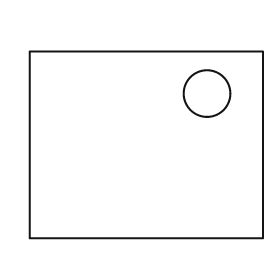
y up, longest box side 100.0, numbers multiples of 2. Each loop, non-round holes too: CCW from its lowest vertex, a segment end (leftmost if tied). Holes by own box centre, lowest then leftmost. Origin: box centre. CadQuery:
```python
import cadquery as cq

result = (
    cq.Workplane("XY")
    .moveTo(-50.0, -40.0)
    .lineTo(50.0, -40.0)
    .lineTo(50.0, 40.0)
    .lineTo(-50.0, 40.0)
    .close()
    .moveTo(26.0, 22.0)
    .circle(10.0)
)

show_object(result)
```